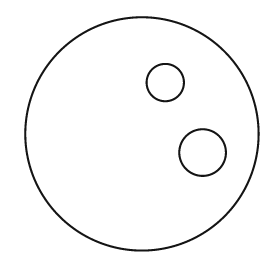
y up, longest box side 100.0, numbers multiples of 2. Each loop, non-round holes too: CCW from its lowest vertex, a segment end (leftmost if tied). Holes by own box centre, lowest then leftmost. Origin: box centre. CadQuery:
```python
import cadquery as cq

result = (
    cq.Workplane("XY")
    .moveTo(0.0, 0.0)
    .circle(50.0)
    .moveTo(26.0, -8.0)
    .circle(10.0)
    .moveTo(10.0, 22.0)
    .circle(8.0)
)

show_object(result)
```